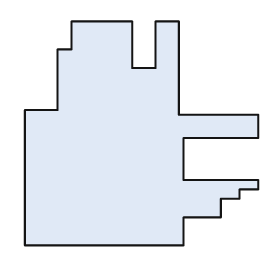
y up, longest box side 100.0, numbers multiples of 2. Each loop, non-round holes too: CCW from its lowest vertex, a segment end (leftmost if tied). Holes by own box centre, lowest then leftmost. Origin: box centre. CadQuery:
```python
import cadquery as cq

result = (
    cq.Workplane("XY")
    .moveTo(-50.0, -48.0)
    .lineTo(18.0, -48.0)
    .lineTo(18.0, -36.0)
    .lineTo(34.0, -36.0)
    .lineTo(34.0, -28.0)
    .lineTo(42.0, -28.0)
    .lineTo(42.0, -24.0)
    .lineTo(50.0, -24.0)
    .lineTo(50.0, -20.0)
    .lineTo(18.0, -20.0)
    .lineTo(18.0, -2.0)
    .lineTo(50.0, -2.0)
    .lineTo(50.0, 8.0)
    .lineTo(16.0, 8.0)
    .lineTo(16.0, 48.0)
    .lineTo(6.0, 48.0)
    .lineTo(6.0, 28.0)
    .lineTo(-4.0, 28.0)
    .lineTo(-4.0, 48.0)
    .lineTo(-30.0, 48.0)
    .lineTo(-30.0, 36.0)
    .lineTo(-36.0, 36.0)
    .lineTo(-36.0, 10.0)
    .lineTo(-50.0, 10.0)
    .close()
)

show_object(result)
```